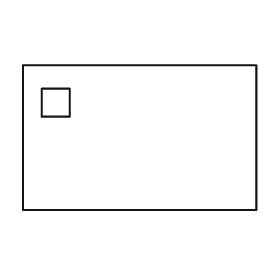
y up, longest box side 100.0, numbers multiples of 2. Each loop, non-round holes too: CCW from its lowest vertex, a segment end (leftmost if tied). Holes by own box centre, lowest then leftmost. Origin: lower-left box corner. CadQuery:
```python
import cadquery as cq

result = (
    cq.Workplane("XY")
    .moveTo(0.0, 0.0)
    .lineTo(100.0, 0.0)
    .lineTo(100.0, 62.0)
    .lineTo(0.0, 62.0)
    .close()
    .moveTo(8.0, 40.0)
    .lineTo(20.0, 40.0)
    .lineTo(20.0, 52.0)
    .lineTo(8.0, 52.0)
    .close()
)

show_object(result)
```